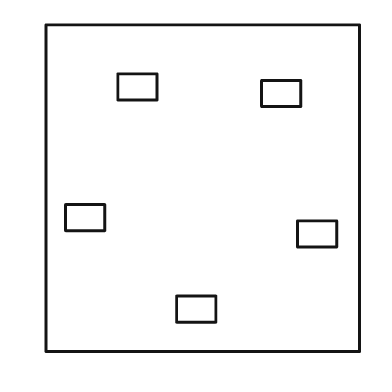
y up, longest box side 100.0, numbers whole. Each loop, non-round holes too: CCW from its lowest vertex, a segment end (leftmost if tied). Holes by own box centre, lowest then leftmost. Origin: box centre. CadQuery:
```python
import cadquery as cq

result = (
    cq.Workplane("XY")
    .moveTo(-48.0, -50.0)
    .lineTo(48.0, -50.0)
    .lineTo(48.0, 50.0)
    .lineTo(-48.0, 50.0)
    .close()
    .moveTo(-8.0, -41.0)
    .lineTo(4.0, -41.0)
    .lineTo(4.0, -33.0)
    .lineTo(-8.0, -33.0)
    .close()
    .moveTo(29.0, -18.0)
    .lineTo(41.0, -18.0)
    .lineTo(41.0, -10.0)
    .lineTo(29.0, -10.0)
    .close()
    .moveTo(-42.0, -13.0)
    .lineTo(-30.0, -13.0)
    .lineTo(-30.0, -5.0)
    .lineTo(-42.0, -5.0)
    .close()
    .moveTo(18.0, 25.0)
    .lineTo(30.0, 25.0)
    .lineTo(30.0, 33.0)
    .lineTo(18.0, 33.0)
    .close()
    .moveTo(-26.0, 27.0)
    .lineTo(-14.0, 27.0)
    .lineTo(-14.0, 35.0)
    .lineTo(-26.0, 35.0)
    .close()
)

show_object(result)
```